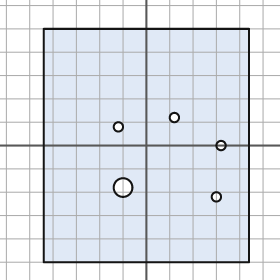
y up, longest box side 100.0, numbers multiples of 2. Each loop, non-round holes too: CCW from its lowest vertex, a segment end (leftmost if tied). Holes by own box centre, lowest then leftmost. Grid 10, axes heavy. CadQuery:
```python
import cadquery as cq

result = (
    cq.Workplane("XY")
    .moveTo(-44.0, -50.0)
    .lineTo(44.0, -50.0)
    .lineTo(44.0, 50.0)
    .lineTo(-44.0, 50.0)
    .close()
    .moveTo(30.0, -22.0)
    .circle(2.0)
    .moveTo(-10.0, -18.0)
    .circle(4.0)
    .moveTo(32.0, 0.0)
    .circle(2.0)
    .moveTo(-12.0, 8.0)
    .circle(2.0)
    .moveTo(12.0, 12.0)
    .circle(2.0)
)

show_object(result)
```